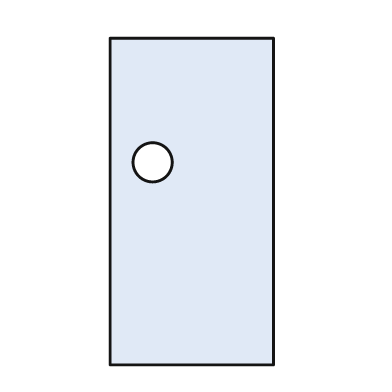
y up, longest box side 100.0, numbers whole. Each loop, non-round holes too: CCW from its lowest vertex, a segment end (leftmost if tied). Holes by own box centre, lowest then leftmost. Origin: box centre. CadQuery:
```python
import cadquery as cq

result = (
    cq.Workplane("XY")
    .moveTo(-25.0, -50.0)
    .lineTo(25.0, -50.0)
    .lineTo(25.0, 50.0)
    .lineTo(-25.0, 50.0)
    .close()
    .moveTo(-12.0, 12.0)
    .circle(6.0)
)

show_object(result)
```